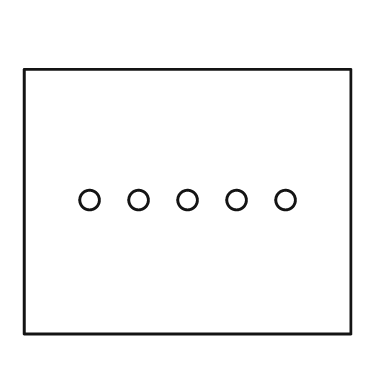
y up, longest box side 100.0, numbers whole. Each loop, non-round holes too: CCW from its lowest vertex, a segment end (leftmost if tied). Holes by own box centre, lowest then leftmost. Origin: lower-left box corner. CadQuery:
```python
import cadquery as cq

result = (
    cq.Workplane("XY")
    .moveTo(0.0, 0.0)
    .lineTo(100.0, 0.0)
    .lineTo(100.0, 81.0)
    .lineTo(0.0, 81.0)
    .close()
    .moveTo(20.0, 41.0)
    .circle(3.0)
    .moveTo(35.0, 41.0)
    .circle(3.0)
    .moveTo(50.0, 41.0)
    .circle(3.0)
    .moveTo(65.0, 41.0)
    .circle(3.0)
    .moveTo(80.0, 41.0)
    .circle(3.0)
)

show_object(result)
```